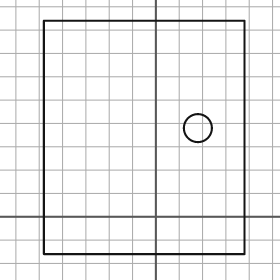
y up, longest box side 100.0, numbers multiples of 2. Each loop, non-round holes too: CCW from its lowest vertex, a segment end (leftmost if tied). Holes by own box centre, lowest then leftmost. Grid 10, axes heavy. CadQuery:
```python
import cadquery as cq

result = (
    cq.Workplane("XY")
    .moveTo(-48.0, -16.0)
    .lineTo(38.0, -16.0)
    .lineTo(38.0, 84.0)
    .lineTo(-48.0, 84.0)
    .close()
    .moveTo(18.0, 38.0)
    .circle(6.0)
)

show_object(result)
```